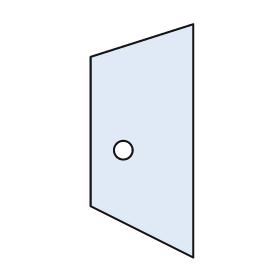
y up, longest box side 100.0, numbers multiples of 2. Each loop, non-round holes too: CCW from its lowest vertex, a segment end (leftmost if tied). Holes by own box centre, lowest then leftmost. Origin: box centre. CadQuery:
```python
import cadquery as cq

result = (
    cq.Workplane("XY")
    .moveTo(22.0, -50.0)
    .lineTo(22.0, 50.0)
    .lineTo(-22.0, 36.0)
    .lineTo(-22.0, -28.0)
    .close()
    .moveTo(-8.0, -4.0)
    .circle(4.0)
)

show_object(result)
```